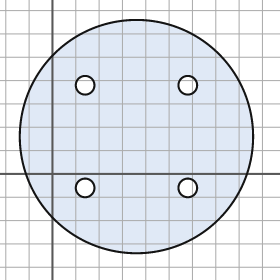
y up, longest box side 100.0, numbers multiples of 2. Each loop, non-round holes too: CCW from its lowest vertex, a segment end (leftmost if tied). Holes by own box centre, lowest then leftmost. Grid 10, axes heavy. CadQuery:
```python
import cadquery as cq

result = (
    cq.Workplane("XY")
    .moveTo(36.0, 16.0)
    .circle(50.0)
    .moveTo(14.0, -6.0)
    .circle(4.0)
    .moveTo(58.0, -6.0)
    .circle(4.0)
    .moveTo(14.0, 38.0)
    .circle(4.0)
    .moveTo(58.0, 38.0)
    .circle(4.0)
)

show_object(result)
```